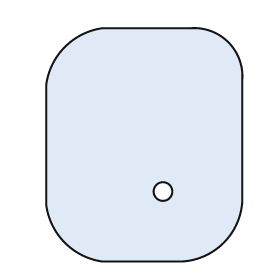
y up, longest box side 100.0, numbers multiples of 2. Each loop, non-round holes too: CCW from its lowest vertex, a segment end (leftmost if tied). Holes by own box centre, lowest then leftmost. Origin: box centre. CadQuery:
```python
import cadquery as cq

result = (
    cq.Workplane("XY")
    .moveTo(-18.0, -50.0)
    .lineTo(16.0, -50.0)
    .threePointArc((34.0, -42.0), (42.0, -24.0))
    .lineTo(42.0, 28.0)
    .threePointArc((36.0, 44.0), (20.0, 50.0))
    .lineTo(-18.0, 50.0)
    .threePointArc((-34.0, 42.0), (-42.0, 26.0))
    .lineTo(-42.0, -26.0)
    .threePointArc((-34.0, -42.0), (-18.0, -50.0))
    .close()
    .moveTo(8.0, -20.0)
    .circle(4.0)
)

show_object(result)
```